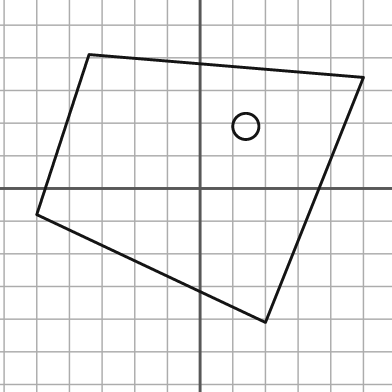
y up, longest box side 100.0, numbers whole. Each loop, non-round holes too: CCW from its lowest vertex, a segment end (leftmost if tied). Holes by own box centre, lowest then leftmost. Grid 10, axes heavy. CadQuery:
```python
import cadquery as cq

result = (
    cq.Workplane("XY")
    .moveTo(20.0, -41.0)
    .lineTo(50.0, 34.0)
    .lineTo(-34.0, 41.0)
    .lineTo(-50.0, -8.0)
    .close()
    .moveTo(14.0, 19.0)
    .circle(4.0)
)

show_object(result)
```